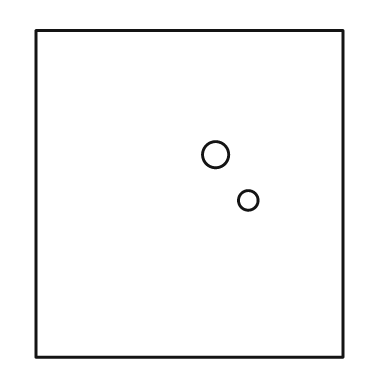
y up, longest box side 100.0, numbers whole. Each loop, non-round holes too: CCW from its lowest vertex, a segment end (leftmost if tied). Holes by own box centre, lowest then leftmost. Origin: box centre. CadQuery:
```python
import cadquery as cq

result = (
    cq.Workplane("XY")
    .moveTo(-47.0, -50.0)
    .lineTo(47.0, -50.0)
    .lineTo(47.0, 50.0)
    .lineTo(-47.0, 50.0)
    .close()
    .moveTo(18.0, -2.0)
    .circle(3.0)
    .moveTo(8.0, 12.0)
    .circle(4.0)
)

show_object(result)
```